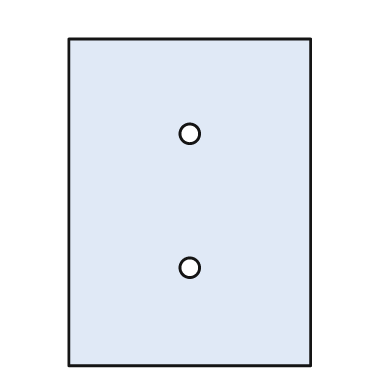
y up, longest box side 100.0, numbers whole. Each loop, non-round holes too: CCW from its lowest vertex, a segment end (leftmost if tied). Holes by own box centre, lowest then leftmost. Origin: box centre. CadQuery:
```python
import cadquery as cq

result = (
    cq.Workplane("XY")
    .moveTo(-37.0, -50.0)
    .lineTo(37.0, -50.0)
    .lineTo(37.0, 50.0)
    .lineTo(-37.0, 50.0)
    .close()
    .moveTo(0.0, -20.0)
    .circle(3.0)
    .moveTo(0.0, 21.0)
    .circle(3.0)
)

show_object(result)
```